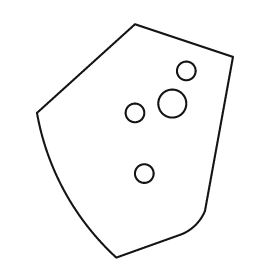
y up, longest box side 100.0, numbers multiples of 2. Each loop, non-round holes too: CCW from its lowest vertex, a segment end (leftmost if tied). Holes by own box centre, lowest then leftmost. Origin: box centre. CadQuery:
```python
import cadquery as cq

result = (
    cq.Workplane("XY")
    .moveTo(-8.0, -50.0)
    .lineTo(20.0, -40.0)
    .threePointArc((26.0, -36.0), (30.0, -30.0))
    .lineTo(42.0, 36.0)
    .lineTo(0.0, 50.0)
    .lineTo(-42.0, 12.0)
    .threePointArc((-30.0, -22.0), (-8.0, -50.0))
    .close()
    .moveTo(4.0, -14.0)
    .circle(4.0)
    .moveTo(0.0, 12.0)
    .circle(4.0)
    .moveTo(16.0, 16.0)
    .circle(6.0)
    .moveTo(22.0, 30.0)
    .circle(4.0)
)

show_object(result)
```